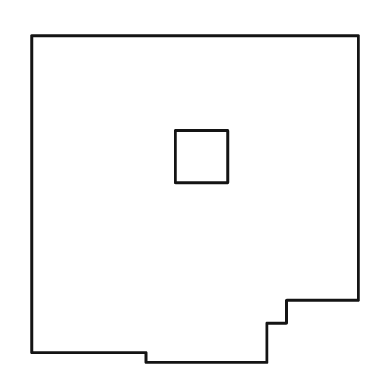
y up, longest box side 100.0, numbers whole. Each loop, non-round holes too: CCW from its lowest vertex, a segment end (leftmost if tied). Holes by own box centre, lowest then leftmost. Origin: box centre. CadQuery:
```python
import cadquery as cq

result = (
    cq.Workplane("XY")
    .moveTo(-15.0, -50.0)
    .lineTo(22.0, -50.0)
    .lineTo(22.0, -38.0)
    .lineTo(28.0, -38.0)
    .lineTo(28.0, -31.0)
    .lineTo(50.0, -31.0)
    .lineTo(50.0, 50.0)
    .lineTo(-50.0, 50.0)
    .lineTo(-50.0, -47.0)
    .lineTo(-15.0, -47.0)
    .close()
    .moveTo(-6.0, 5.0)
    .lineTo(10.0, 5.0)
    .lineTo(10.0, 21.0)
    .lineTo(-6.0, 21.0)
    .close()
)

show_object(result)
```